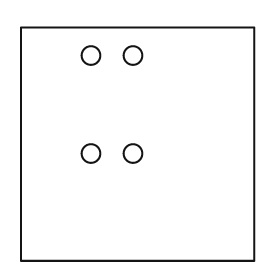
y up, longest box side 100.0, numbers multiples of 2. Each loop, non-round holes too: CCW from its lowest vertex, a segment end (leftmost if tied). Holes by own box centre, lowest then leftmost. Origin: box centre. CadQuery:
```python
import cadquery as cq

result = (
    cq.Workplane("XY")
    .moveTo(-50.0, -50.0)
    .lineTo(50.0, -50.0)
    .lineTo(50.0, 50.0)
    .lineTo(-50.0, 50.0)
    .close()
    .moveTo(-20.0, -4.0)
    .circle(4.0)
    .moveTo(-2.0, -4.0)
    .circle(4.0)
    .moveTo(-20.0, 38.0)
    .circle(4.0)
    .moveTo(-2.0, 38.0)
    .circle(4.0)
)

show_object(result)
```